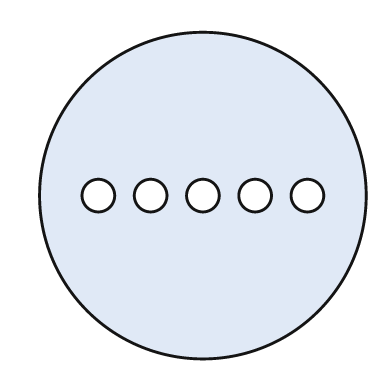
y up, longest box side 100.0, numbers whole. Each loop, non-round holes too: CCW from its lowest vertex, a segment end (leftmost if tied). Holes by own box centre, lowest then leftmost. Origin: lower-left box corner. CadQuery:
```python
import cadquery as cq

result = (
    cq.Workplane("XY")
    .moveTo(50.0, 50.0)
    .circle(50.0)
    .moveTo(18.0, 50.0)
    .circle(5.0)
    .moveTo(34.0, 50.0)
    .circle(5.0)
    .moveTo(50.0, 50.0)
    .circle(5.0)
    .moveTo(66.0, 50.0)
    .circle(5.0)
    .moveTo(82.0, 50.0)
    .circle(5.0)
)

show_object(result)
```